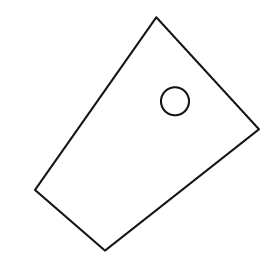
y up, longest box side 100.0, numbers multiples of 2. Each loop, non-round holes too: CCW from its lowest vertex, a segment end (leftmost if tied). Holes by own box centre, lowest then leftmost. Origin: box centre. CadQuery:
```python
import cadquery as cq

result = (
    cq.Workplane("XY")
    .moveTo(-18.0, -50.0)
    .lineTo(48.0, 2.0)
    .lineTo(4.0, 50.0)
    .lineTo(-48.0, -24.0)
    .close()
    .moveTo(12.0, 14.0)
    .circle(6.0)
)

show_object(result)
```